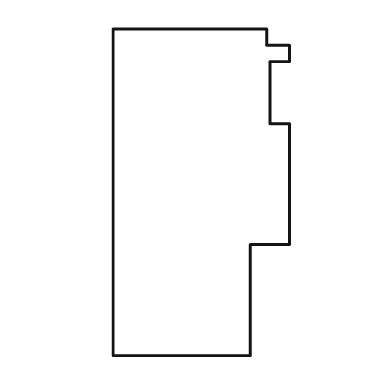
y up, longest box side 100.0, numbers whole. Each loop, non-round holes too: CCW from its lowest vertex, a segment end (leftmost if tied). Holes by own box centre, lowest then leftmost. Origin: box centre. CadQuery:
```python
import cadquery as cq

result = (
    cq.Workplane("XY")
    .moveTo(-27.0, -50.0)
    .lineTo(15.0, -50.0)
    .lineTo(15.0, -16.0)
    .lineTo(27.0, -16.0)
    .lineTo(27.0, 21.0)
    .lineTo(21.0, 21.0)
    .lineTo(21.0, 40.0)
    .lineTo(27.0, 40.0)
    .lineTo(27.0, 45.0)
    .lineTo(20.0, 45.0)
    .lineTo(20.0, 50.0)
    .lineTo(-27.0, 50.0)
    .close()
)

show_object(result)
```